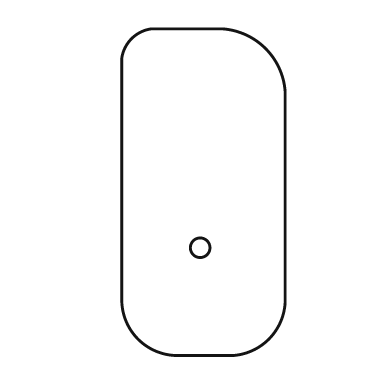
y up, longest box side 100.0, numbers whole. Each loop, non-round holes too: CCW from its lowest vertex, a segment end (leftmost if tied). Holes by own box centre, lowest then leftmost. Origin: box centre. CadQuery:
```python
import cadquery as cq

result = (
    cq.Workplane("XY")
    .moveTo(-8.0, -50.0)
    .lineTo(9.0, -50.0)
    .threePointArc((20.0, -45.0), (25.0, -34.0))
    .lineTo(25.0, 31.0)
    .threePointArc((19.0, 44.0), (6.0, 50.0))
    .lineTo(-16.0, 50.0)
    .threePointArc((-22.0, 47.0), (-25.0, 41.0))
    .lineTo(-25.0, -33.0)
    .threePointArc((-20.0, -45.0), (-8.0, -50.0))
    .close()
    .moveTo(-1.0, -17.0)
    .circle(3.0)
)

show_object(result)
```